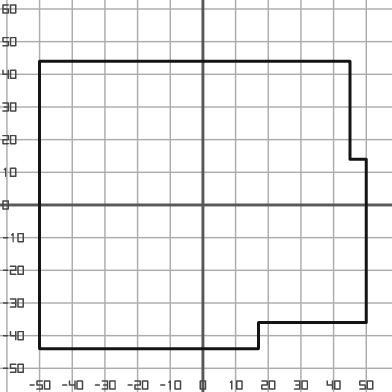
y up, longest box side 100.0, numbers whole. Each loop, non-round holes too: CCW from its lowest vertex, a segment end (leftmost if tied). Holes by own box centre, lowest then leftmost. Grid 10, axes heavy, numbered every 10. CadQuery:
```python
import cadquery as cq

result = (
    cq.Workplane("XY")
    .moveTo(-50.0, -44.0)
    .lineTo(17.0, -44.0)
    .lineTo(17.0, -36.0)
    .lineTo(50.0, -36.0)
    .lineTo(50.0, 14.0)
    .lineTo(45.0, 14.0)
    .lineTo(45.0, 44.0)
    .lineTo(-50.0, 44.0)
    .close()
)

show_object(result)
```